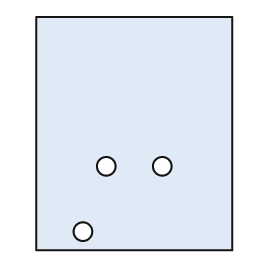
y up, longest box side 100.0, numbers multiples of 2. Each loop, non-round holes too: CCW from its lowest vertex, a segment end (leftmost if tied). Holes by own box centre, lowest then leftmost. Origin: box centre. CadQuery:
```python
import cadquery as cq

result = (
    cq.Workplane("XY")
    .moveTo(-42.0, -50.0)
    .lineTo(42.0, -50.0)
    .lineTo(42.0, 50.0)
    .lineTo(-42.0, 50.0)
    .close()
    .moveTo(-22.0, -42.0)
    .circle(4.0)
    .moveTo(-12.0, -14.0)
    .circle(4.0)
    .moveTo(12.0, -14.0)
    .circle(4.0)
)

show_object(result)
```